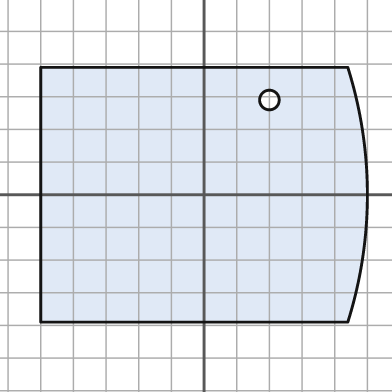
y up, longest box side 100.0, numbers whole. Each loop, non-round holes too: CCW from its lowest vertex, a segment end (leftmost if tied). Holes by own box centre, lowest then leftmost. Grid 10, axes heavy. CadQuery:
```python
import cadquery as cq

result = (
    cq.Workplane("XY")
    .moveTo(-50.0, -39.0)
    .lineTo(44.0, -39.0)
    .threePointArc((50.0, 0.0), (44.0, 39.0))
    .lineTo(-50.0, 39.0)
    .close()
    .moveTo(20.0, 29.0)
    .circle(3.0)
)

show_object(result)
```